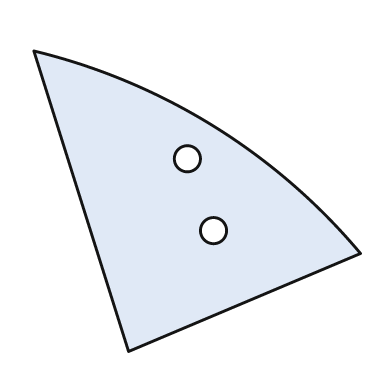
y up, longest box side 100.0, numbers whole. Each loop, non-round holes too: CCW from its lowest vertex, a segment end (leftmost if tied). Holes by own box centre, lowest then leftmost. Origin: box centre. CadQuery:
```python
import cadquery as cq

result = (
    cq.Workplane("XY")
    .moveTo(-21.0, -46.0)
    .lineTo(50.0, -16.0)
    .threePointArc((5.0, 23.0), (-50.0, 46.0))
    .close()
    .moveTo(5.0, -9.0)
    .circle(4.0)
    .moveTo(-3.0, 13.0)
    .circle(4.0)
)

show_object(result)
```